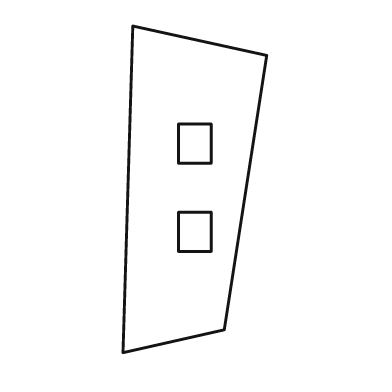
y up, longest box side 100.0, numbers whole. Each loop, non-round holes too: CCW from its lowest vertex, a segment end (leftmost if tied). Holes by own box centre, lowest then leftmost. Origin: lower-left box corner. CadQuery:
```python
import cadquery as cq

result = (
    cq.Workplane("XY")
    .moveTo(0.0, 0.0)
    .lineTo(31.0, 7.0)
    .lineTo(44.0, 91.0)
    .lineTo(3.0, 100.0)
    .close()
    .moveTo(17.0, 31.0)
    .lineTo(27.0, 31.0)
    .lineTo(27.0, 43.0)
    .lineTo(17.0, 43.0)
    .close()
    .moveTo(17.0, 58.0)
    .lineTo(27.0, 58.0)
    .lineTo(27.0, 70.0)
    .lineTo(17.0, 70.0)
    .close()
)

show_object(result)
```